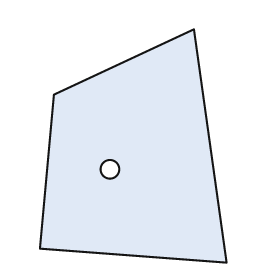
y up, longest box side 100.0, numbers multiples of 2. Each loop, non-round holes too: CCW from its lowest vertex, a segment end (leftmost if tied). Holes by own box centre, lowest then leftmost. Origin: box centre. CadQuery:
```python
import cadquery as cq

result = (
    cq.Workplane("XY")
    .moveTo(40.0, -50.0)
    .lineTo(26.0, 50.0)
    .lineTo(-34.0, 22.0)
    .lineTo(-40.0, -44.0)
    .close()
    .moveTo(-10.0, -10.0)
    .circle(4.0)
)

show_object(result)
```